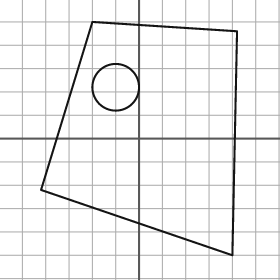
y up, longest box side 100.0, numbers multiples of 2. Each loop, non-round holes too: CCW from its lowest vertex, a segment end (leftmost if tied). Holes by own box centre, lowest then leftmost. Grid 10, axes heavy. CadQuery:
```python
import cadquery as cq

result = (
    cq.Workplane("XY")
    .moveTo(40.0, -50.0)
    .lineTo(42.0, 46.0)
    .lineTo(-20.0, 50.0)
    .lineTo(-42.0, -22.0)
    .close()
    .moveTo(-10.0, 22.0)
    .circle(10.0)
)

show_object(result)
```